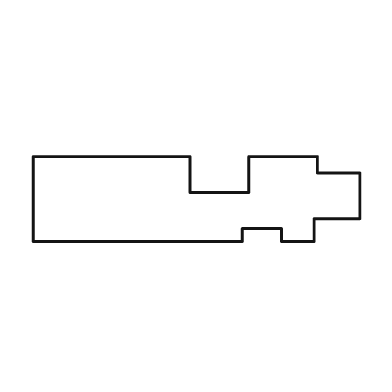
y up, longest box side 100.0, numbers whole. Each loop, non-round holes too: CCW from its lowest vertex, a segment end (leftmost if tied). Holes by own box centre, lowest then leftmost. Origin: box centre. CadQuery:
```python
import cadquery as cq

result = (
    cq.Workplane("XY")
    .moveTo(-50.0, -13.0)
    .lineTo(14.0, -13.0)
    .lineTo(14.0, -9.0)
    .lineTo(26.0, -9.0)
    .lineTo(26.0, -13.0)
    .lineTo(36.0, -13.0)
    .lineTo(36.0, -6.0)
    .lineTo(50.0, -6.0)
    .lineTo(50.0, 8.0)
    .lineTo(37.0, 8.0)
    .lineTo(37.0, 13.0)
    .lineTo(16.0, 13.0)
    .lineTo(16.0, 2.0)
    .lineTo(-2.0, 2.0)
    .lineTo(-2.0, 13.0)
    .lineTo(-50.0, 13.0)
    .close()
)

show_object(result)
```